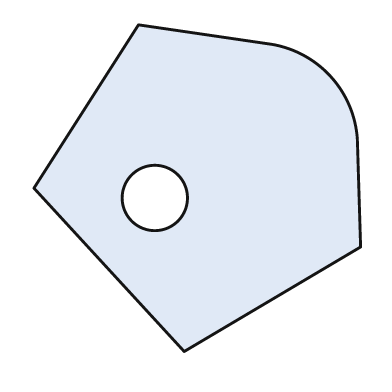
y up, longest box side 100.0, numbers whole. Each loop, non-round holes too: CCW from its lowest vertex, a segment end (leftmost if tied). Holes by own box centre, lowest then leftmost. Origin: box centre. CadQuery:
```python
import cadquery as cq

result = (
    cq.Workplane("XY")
    .moveTo(-4.0, -50.0)
    .lineTo(50.0, -18.0)
    .lineTo(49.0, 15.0)
    .threePointArc((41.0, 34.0), (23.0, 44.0))
    .lineTo(-18.0, 50.0)
    .lineTo(-50.0, 0.0)
    .close()
    .moveTo(-13.0, -3.0)
    .circle(10.0)
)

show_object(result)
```